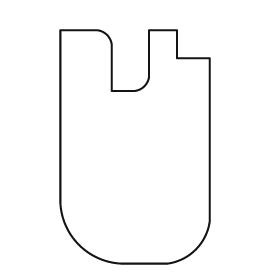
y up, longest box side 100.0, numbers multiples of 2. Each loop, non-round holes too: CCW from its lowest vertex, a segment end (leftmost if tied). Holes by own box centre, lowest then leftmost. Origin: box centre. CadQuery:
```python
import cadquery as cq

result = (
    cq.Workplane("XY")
    .moveTo(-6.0, -50.0)
    .lineTo(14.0, -50.0)
    .threePointArc((26.0, -44.0), (32.0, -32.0))
    .lineTo(32.0, 38.0)
    .lineTo(18.0, 38.0)
    .lineTo(18.0, 50.0)
    .lineTo(6.0, 50.0)
    .lineTo(6.0, 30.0)
    .threePointArc((4.0, 26.0), (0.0, 24.0))
    .lineTo(-10.0, 24.0)
    .lineTo(-10.0, 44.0)
    .threePointArc((-12.0, 48.0), (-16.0, 50.0))
    .lineTo(-32.0, 50.0)
    .lineTo(-32.0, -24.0)
    .threePointArc((-24.0, -42.0), (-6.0, -50.0))
    .close()
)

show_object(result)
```